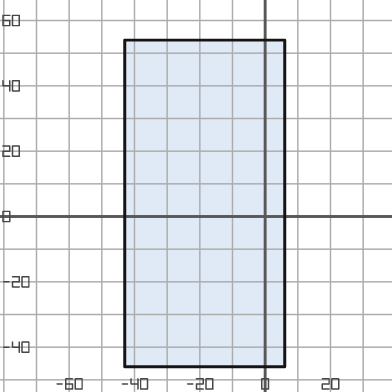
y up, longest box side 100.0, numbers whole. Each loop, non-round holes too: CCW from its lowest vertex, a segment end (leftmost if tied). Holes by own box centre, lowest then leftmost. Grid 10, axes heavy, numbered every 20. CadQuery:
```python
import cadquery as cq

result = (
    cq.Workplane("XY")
    .moveTo(-43.0, -46.0)
    .lineTo(6.0, -46.0)
    .lineTo(6.0, 54.0)
    .lineTo(-43.0, 54.0)
    .close()
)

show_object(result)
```